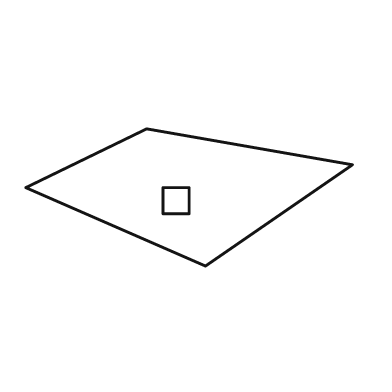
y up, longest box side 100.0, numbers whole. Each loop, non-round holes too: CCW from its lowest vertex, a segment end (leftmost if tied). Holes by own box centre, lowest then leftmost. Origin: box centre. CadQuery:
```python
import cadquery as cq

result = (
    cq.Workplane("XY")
    .moveTo(5.0, -21.0)
    .lineTo(50.0, 10.0)
    .lineTo(-13.0, 21.0)
    .lineTo(-50.0, 3.0)
    .close()
    .moveTo(-8.0, -5.0)
    .lineTo(0.0, -5.0)
    .lineTo(0.0, 3.0)
    .lineTo(-8.0, 3.0)
    .close()
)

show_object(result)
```